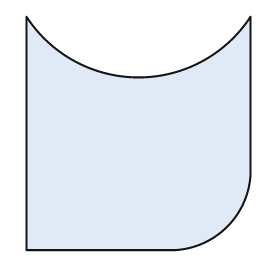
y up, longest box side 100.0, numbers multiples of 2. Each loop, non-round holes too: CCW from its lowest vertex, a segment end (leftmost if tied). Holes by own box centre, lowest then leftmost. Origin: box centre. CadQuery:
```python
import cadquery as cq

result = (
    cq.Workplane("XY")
    .moveTo(-48.0, -50.0)
    .lineTo(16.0, -50.0)
    .threePointArc((38.0, -40.0), (48.0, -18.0))
    .lineTo(48.0, 50.0)
    .threePointArc((0.0, 24.0), (-48.0, 50.0))
    .close()
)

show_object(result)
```